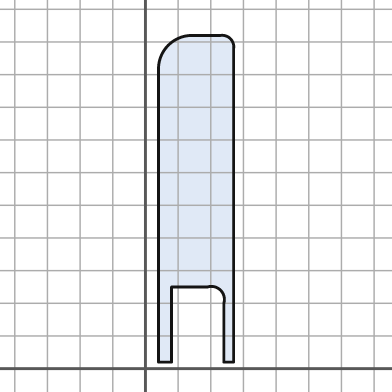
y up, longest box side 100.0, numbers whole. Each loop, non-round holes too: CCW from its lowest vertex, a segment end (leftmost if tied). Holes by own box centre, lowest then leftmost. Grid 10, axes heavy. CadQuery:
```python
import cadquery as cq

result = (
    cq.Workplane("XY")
    .moveTo(4.0, 2.0)
    .lineTo(8.0, 2.0)
    .lineTo(8.0, 25.0)
    .lineTo(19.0, 25.0)
    .threePointArc((23.0, 24.0), (24.0, 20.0))
    .lineTo(24.0, 2.0)
    .lineTo(27.0, 2.0)
    .lineTo(27.0, 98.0)
    .threePointArc((26.0, 101.0), (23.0, 102.0))
    .lineTo(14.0, 102.0)
    .threePointArc((7.0, 99.0), (4.0, 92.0))
    .close()
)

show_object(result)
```